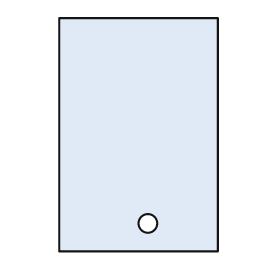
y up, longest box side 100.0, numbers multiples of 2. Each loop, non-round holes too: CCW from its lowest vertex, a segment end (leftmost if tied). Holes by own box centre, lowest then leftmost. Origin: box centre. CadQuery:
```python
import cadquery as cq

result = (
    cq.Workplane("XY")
    .moveTo(-34.0, -50.0)
    .lineTo(34.0, -50.0)
    .lineTo(34.0, 50.0)
    .lineTo(-34.0, 50.0)
    .close()
    .moveTo(4.0, -38.0)
    .circle(4.0)
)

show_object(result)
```